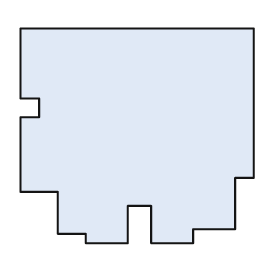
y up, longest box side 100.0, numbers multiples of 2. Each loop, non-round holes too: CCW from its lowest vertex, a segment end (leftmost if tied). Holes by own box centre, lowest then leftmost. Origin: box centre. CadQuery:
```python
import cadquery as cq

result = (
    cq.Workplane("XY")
    .moveTo(-22.0, -46.0)
    .lineTo(-4.0, -46.0)
    .lineTo(-4.0, -30.0)
    .lineTo(6.0, -30.0)
    .lineTo(6.0, -46.0)
    .lineTo(24.0, -46.0)
    .lineTo(24.0, -40.0)
    .lineTo(42.0, -40.0)
    .lineTo(42.0, -18.0)
    .lineTo(50.0, -18.0)
    .lineTo(50.0, 46.0)
    .lineTo(-50.0, 46.0)
    .lineTo(-50.0, 16.0)
    .lineTo(-42.0, 16.0)
    .lineTo(-42.0, 8.0)
    .lineTo(-50.0, 8.0)
    .lineTo(-50.0, -24.0)
    .lineTo(-34.0, -24.0)
    .lineTo(-34.0, -42.0)
    .lineTo(-22.0, -42.0)
    .close()
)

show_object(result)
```